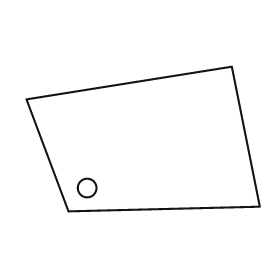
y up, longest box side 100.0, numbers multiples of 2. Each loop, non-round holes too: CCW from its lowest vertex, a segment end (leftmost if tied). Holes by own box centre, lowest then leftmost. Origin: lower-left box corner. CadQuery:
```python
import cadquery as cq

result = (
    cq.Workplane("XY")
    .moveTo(18.0, 0.0)
    .lineTo(100.0, 2.0)
    .lineTo(88.0, 62.0)
    .lineTo(0.0, 48.0)
    .close()
    .moveTo(26.0, 10.0)
    .circle(4.0)
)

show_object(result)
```